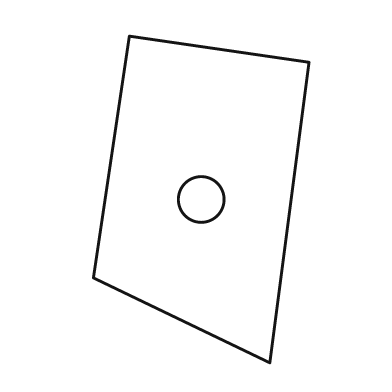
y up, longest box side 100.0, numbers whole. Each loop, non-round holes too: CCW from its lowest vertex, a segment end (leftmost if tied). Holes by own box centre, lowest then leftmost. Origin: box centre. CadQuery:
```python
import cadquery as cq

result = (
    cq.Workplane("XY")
    .moveTo(21.0, -50.0)
    .lineTo(33.0, 42.0)
    .lineTo(-22.0, 50.0)
    .lineTo(-33.0, -24.0)
    .close()
    .moveTo(0.0, 0.0)
    .circle(7.0)
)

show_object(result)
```